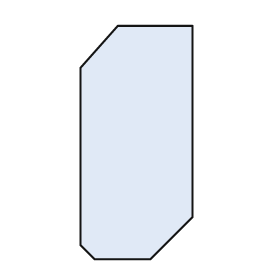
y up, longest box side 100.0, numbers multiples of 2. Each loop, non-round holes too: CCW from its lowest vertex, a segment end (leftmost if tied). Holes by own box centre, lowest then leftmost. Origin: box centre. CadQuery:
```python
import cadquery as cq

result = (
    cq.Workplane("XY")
    .moveTo(-18.0, -50.0)
    .lineTo(6.0, -50.0)
    .lineTo(24.0, -32.0)
    .lineTo(24.0, 50.0)
    .lineTo(-8.0, 50.0)
    .lineTo(-24.0, 32.0)
    .lineTo(-24.0, -44.0)
    .close()
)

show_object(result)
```